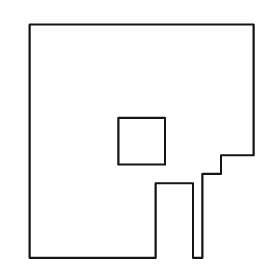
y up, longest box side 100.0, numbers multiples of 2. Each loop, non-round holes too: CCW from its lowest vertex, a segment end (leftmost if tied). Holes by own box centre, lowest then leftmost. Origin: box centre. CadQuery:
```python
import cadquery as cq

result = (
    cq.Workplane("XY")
    .moveTo(-48.0, -50.0)
    .lineTo(6.0, -50.0)
    .lineTo(6.0, -18.0)
    .lineTo(22.0, -18.0)
    .lineTo(22.0, -50.0)
    .lineTo(26.0, -50.0)
    .lineTo(26.0, -14.0)
    .lineTo(34.0, -14.0)
    .lineTo(34.0, -6.0)
    .lineTo(48.0, -6.0)
    .lineTo(48.0, 50.0)
    .lineTo(-48.0, 50.0)
    .close()
    .moveTo(-10.0, -10.0)
    .lineTo(10.0, -10.0)
    .lineTo(10.0, 10.0)
    .lineTo(-10.0, 10.0)
    .close()
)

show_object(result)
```